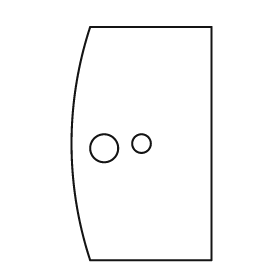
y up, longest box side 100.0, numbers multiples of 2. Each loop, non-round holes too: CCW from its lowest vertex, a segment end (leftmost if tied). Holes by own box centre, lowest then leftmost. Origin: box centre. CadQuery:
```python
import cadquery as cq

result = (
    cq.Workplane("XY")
    .moveTo(-22.0, -50.0)
    .lineTo(30.0, -50.0)
    .lineTo(30.0, 50.0)
    .lineTo(-22.0, 50.0)
    .threePointArc((-30.0, 0.0), (-22.0, -50.0))
    .close()
    .moveTo(-16.0, -2.0)
    .circle(6.0)
    .moveTo(0.0, 0.0)
    .circle(4.0)
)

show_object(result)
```